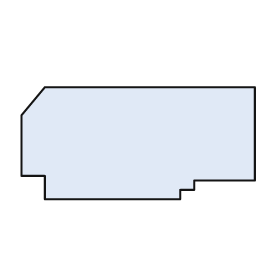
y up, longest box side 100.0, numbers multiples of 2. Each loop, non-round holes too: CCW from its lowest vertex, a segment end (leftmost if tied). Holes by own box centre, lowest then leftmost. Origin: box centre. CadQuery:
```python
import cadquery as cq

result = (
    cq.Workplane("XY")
    .moveTo(-40.0, -24.0)
    .lineTo(18.0, -24.0)
    .lineTo(18.0, -20.0)
    .lineTo(24.0, -20.0)
    .lineTo(24.0, -16.0)
    .lineTo(50.0, -16.0)
    .lineTo(50.0, 24.0)
    .lineTo(-40.0, 24.0)
    .lineTo(-50.0, 12.0)
    .lineTo(-50.0, -14.0)
    .lineTo(-40.0, -14.0)
    .close()
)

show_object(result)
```